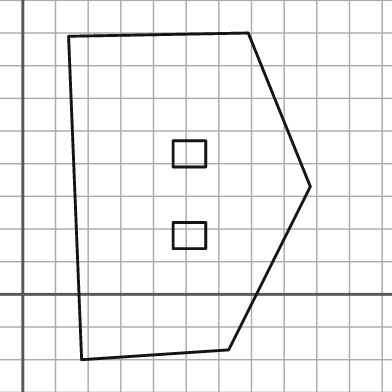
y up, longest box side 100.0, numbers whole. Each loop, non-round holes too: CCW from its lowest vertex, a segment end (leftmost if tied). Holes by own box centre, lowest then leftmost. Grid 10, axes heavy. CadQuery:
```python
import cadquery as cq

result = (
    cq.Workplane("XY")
    .moveTo(18.0, -20.0)
    .lineTo(63.0, -17.0)
    .lineTo(88.0, 33.0)
    .lineTo(69.0, 80.0)
    .lineTo(14.0, 79.0)
    .close()
    .moveTo(46.0, 14.0)
    .lineTo(56.0, 14.0)
    .lineTo(56.0, 22.0)
    .lineTo(46.0, 22.0)
    .close()
    .moveTo(46.0, 39.0)
    .lineTo(56.0, 39.0)
    .lineTo(56.0, 47.0)
    .lineTo(46.0, 47.0)
    .close()
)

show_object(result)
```